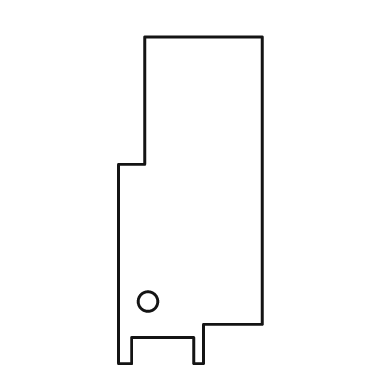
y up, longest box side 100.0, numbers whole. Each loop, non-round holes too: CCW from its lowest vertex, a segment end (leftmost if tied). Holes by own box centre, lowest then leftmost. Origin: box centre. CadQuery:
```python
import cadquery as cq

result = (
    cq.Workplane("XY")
    .moveTo(-22.0, -50.0)
    .lineTo(-18.0, -50.0)
    .lineTo(-18.0, -42.0)
    .lineTo(1.0, -42.0)
    .lineTo(1.0, -50.0)
    .lineTo(4.0, -50.0)
    .lineTo(4.0, -38.0)
    .lineTo(22.0, -38.0)
    .lineTo(22.0, 50.0)
    .lineTo(-14.0, 50.0)
    .lineTo(-14.0, 11.0)
    .lineTo(-22.0, 11.0)
    .close()
    .moveTo(-13.0, -31.0)
    .circle(3.0)
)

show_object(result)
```